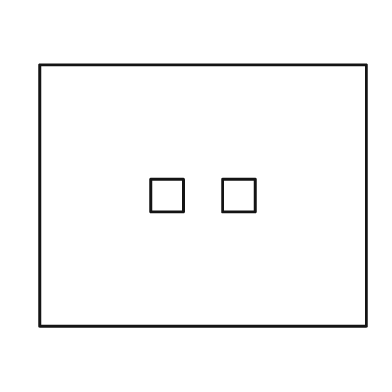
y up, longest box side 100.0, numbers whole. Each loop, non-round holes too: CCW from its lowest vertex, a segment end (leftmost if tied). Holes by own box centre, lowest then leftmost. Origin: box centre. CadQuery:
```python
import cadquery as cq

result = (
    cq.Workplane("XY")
    .moveTo(-50.0, -40.0)
    .lineTo(50.0, -40.0)
    .lineTo(50.0, 40.0)
    .lineTo(-50.0, 40.0)
    .close()
    .moveTo(-16.0, -5.0)
    .lineTo(-6.0, -5.0)
    .lineTo(-6.0, 5.0)
    .lineTo(-16.0, 5.0)
    .close()
    .moveTo(6.0, -5.0)
    .lineTo(16.0, -5.0)
    .lineTo(16.0, 5.0)
    .lineTo(6.0, 5.0)
    .close()
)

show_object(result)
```